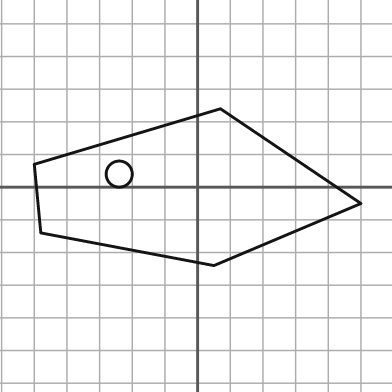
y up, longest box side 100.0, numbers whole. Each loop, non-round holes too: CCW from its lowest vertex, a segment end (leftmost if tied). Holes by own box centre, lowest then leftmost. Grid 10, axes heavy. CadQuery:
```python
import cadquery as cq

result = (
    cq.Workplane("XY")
    .moveTo(5.0, -24.0)
    .lineTo(50.0, -5.0)
    .lineTo(7.0, 24.0)
    .lineTo(-50.0, 7.0)
    .lineTo(-48.0, -14.0)
    .close()
    .moveTo(-24.0, 4.0)
    .circle(4.0)
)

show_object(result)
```